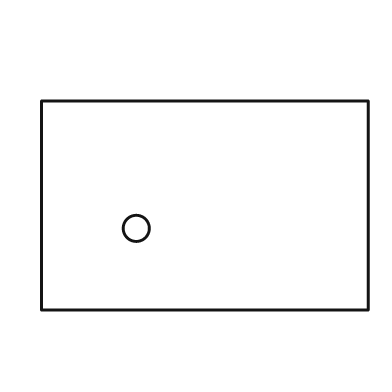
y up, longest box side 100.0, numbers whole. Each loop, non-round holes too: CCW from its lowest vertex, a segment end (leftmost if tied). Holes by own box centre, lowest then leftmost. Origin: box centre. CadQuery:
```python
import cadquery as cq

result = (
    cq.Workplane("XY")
    .moveTo(-50.0, -32.0)
    .lineTo(50.0, -32.0)
    .lineTo(50.0, 32.0)
    .lineTo(-50.0, 32.0)
    .close()
    .moveTo(-21.0, -7.0)
    .circle(4.0)
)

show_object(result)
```